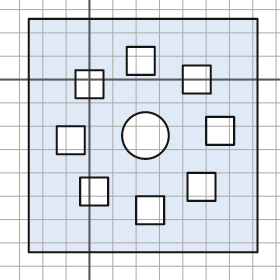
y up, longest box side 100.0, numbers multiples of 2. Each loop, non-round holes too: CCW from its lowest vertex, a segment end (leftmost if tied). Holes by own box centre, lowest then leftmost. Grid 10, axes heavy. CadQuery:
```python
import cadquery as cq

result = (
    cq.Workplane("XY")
    .moveTo(-26.0, -74.0)
    .lineTo(72.0, -74.0)
    .lineTo(72.0, 26.0)
    .lineTo(-26.0, 26.0)
    .close()
    .moveTo(20.0, -62.0)
    .lineTo(32.0, -62.0)
    .lineTo(32.0, -50.0)
    .lineTo(20.0, -50.0)
    .close()
    .moveTo(-4.0, -54.0)
    .lineTo(8.0, -54.0)
    .lineTo(8.0, -42.0)
    .lineTo(-4.0, -42.0)
    .close()
    .moveTo(42.0, -52.0)
    .lineTo(54.0, -52.0)
    .lineTo(54.0, -40.0)
    .lineTo(42.0, -40.0)
    .close()
    .moveTo(-14.0, -32.0)
    .lineTo(-2.0, -32.0)
    .lineTo(-2.0, -20.0)
    .lineTo(-14.0, -20.0)
    .close()
    .moveTo(24.0, -24.0)
    .circle(10.0)
    .moveTo(50.0, -28.0)
    .lineTo(62.0, -28.0)
    .lineTo(62.0, -16.0)
    .lineTo(50.0, -16.0)
    .close()
    .moveTo(-6.0, -8.0)
    .lineTo(6.0, -8.0)
    .lineTo(6.0, 4.0)
    .lineTo(-6.0, 4.0)
    .close()
    .moveTo(40.0, -6.0)
    .lineTo(52.0, -6.0)
    .lineTo(52.0, 6.0)
    .lineTo(40.0, 6.0)
    .close()
    .moveTo(16.0, 2.0)
    .lineTo(28.0, 2.0)
    .lineTo(28.0, 14.0)
    .lineTo(16.0, 14.0)
    .close()
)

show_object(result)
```